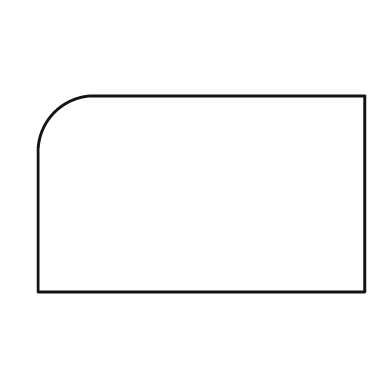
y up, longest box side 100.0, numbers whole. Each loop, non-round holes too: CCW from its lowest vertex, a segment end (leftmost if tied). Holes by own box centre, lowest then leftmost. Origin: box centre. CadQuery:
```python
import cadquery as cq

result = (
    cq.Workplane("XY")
    .moveTo(-50.0, -30.0)
    .lineTo(50.0, -30.0)
    .lineTo(50.0, 30.0)
    .lineTo(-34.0, 30.0)
    .threePointArc((-45.0, 25.0), (-50.0, 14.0))
    .close()
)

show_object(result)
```